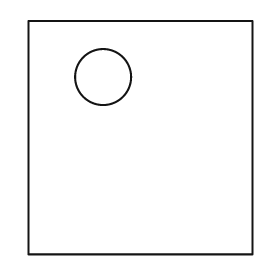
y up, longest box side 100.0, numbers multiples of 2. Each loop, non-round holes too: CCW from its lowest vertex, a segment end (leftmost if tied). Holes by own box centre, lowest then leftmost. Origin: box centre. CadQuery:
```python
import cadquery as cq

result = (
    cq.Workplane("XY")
    .moveTo(-48.0, -50.0)
    .lineTo(48.0, -50.0)
    .lineTo(48.0, 50.0)
    .lineTo(-48.0, 50.0)
    .close()
    .moveTo(-16.0, 26.0)
    .circle(12.0)
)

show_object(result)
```